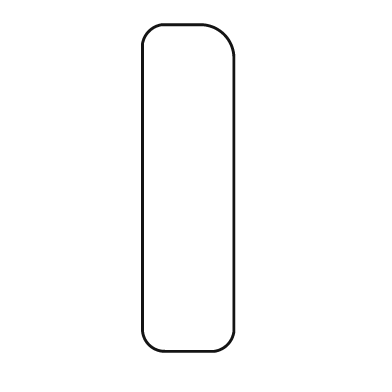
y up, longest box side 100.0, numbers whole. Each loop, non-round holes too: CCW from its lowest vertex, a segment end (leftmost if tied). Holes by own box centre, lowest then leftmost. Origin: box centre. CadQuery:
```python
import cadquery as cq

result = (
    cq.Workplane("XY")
    .moveTo(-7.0, -50.0)
    .lineTo(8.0, -50.0)
    .threePointArc((12.0, -48.0), (14.0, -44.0))
    .lineTo(14.0, 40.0)
    .threePointArc((11.0, 47.0), (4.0, 50.0))
    .lineTo(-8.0, 50.0)
    .threePointArc((-12.0, 48.0), (-14.0, 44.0))
    .lineTo(-14.0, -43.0)
    .threePointArc((-12.0, -48.0), (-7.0, -50.0))
    .close()
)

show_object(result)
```